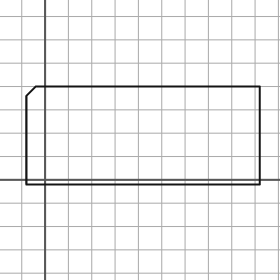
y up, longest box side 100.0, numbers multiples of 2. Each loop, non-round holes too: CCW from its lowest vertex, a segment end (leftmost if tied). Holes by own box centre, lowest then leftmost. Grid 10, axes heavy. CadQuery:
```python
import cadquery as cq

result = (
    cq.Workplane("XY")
    .moveTo(-8.0, -2.0)
    .lineTo(92.0, -2.0)
    .lineTo(92.0, 40.0)
    .lineTo(-4.0, 40.0)
    .lineTo(-8.0, 36.0)
    .close()
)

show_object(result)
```